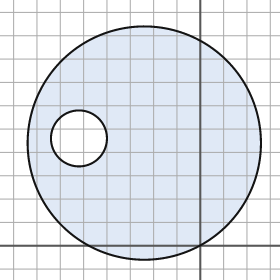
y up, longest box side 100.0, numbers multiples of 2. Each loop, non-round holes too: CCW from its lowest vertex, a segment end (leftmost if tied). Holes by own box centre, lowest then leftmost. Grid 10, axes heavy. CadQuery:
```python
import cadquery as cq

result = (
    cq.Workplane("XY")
    .moveTo(-24.0, 44.0)
    .circle(50.0)
    .moveTo(-52.0, 46.0)
    .circle(12.0)
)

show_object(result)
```